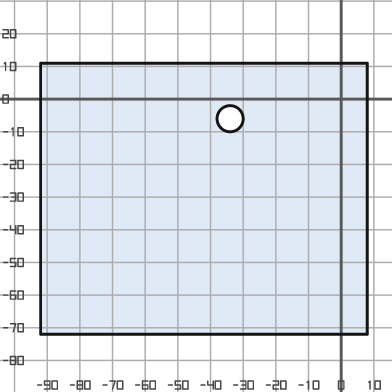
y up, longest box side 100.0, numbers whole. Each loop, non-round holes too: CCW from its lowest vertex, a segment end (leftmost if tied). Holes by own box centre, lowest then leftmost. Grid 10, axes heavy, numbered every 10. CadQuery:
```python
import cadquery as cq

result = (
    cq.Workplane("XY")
    .moveTo(-92.0, -72.0)
    .lineTo(8.0, -72.0)
    .lineTo(8.0, 11.0)
    .lineTo(-92.0, 11.0)
    .close()
    .moveTo(-34.0, -6.0)
    .circle(4.0)
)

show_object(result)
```